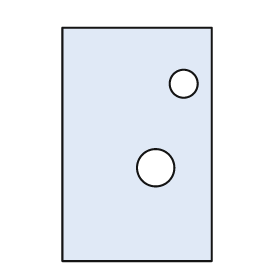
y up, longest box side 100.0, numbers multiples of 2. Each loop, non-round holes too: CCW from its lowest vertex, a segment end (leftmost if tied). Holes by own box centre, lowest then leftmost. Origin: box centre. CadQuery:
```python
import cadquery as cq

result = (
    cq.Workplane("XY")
    .moveTo(-32.0, -50.0)
    .lineTo(32.0, -50.0)
    .lineTo(32.0, 50.0)
    .lineTo(-32.0, 50.0)
    .close()
    .moveTo(8.0, -10.0)
    .circle(8.0)
    .moveTo(20.0, 26.0)
    .circle(6.0)
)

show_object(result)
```